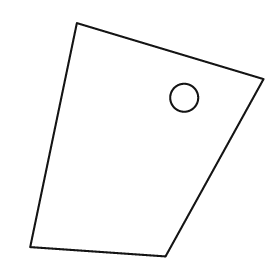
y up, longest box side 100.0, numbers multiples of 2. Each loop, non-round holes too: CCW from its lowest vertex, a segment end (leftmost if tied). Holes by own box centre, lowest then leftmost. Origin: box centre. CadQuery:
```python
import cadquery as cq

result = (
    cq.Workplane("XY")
    .moveTo(8.0, -50.0)
    .lineTo(50.0, 26.0)
    .lineTo(-30.0, 50.0)
    .lineTo(-50.0, -46.0)
    .close()
    .moveTo(16.0, 18.0)
    .circle(6.0)
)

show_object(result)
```